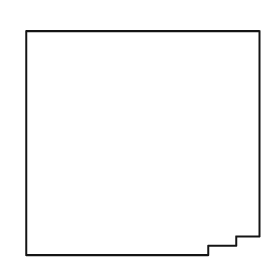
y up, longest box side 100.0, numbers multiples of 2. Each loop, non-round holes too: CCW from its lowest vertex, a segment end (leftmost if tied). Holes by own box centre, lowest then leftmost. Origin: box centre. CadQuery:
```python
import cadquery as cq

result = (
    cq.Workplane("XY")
    .moveTo(-50.0, -48.0)
    .lineTo(28.0, -48.0)
    .lineTo(28.0, -44.0)
    .lineTo(40.0, -44.0)
    .lineTo(40.0, -40.0)
    .lineTo(50.0, -40.0)
    .lineTo(50.0, 48.0)
    .lineTo(-50.0, 48.0)
    .close()
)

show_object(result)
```